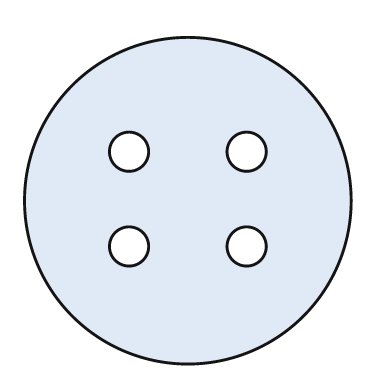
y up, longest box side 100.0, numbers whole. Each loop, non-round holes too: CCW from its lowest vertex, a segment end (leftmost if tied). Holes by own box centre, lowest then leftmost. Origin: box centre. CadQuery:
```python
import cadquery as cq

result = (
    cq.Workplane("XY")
    .moveTo(0.0, 0.0)
    .circle(50.0)
    .moveTo(-18.0, -14.0)
    .circle(6.0)
    .moveTo(18.0, -14.0)
    .circle(6.0)
    .moveTo(-18.0, 15.0)
    .circle(6.0)
    .moveTo(18.0, 15.0)
    .circle(6.0)
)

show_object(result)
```